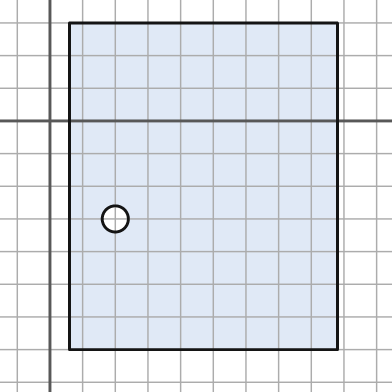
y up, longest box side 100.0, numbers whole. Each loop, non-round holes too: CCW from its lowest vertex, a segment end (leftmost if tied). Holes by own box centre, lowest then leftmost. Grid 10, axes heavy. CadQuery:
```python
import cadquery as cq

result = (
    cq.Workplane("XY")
    .moveTo(6.0, -70.0)
    .lineTo(88.0, -70.0)
    .lineTo(88.0, 30.0)
    .lineTo(6.0, 30.0)
    .close()
    .moveTo(20.0, -30.0)
    .circle(4.0)
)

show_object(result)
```